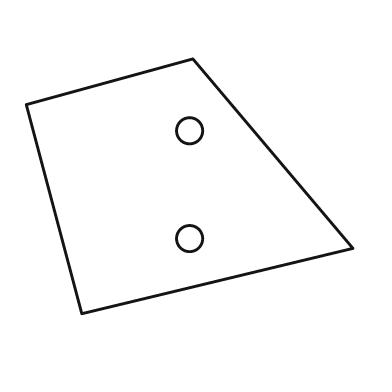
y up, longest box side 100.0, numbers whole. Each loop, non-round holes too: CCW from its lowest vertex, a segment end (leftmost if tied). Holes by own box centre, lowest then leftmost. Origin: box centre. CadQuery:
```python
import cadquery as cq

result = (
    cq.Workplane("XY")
    .moveTo(-33.0, -39.0)
    .lineTo(50.0, -19.0)
    .lineTo(1.0, 39.0)
    .lineTo(-50.0, 25.0)
    .close()
    .moveTo(0.0, -16.0)
    .circle(4.0)
    .moveTo(0.0, 17.0)
    .circle(4.0)
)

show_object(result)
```